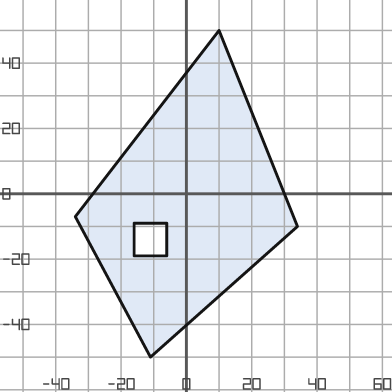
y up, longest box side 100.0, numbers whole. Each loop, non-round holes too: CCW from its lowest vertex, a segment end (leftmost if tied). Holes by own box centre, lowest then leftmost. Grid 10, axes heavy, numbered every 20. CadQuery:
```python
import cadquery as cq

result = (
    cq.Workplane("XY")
    .moveTo(-11.0, -50.0)
    .lineTo(34.0, -10.0)
    .lineTo(10.0, 50.0)
    .lineTo(-34.0, -7.0)
    .close()
    .moveTo(-16.0, -19.0)
    .lineTo(-6.0, -19.0)
    .lineTo(-6.0, -9.0)
    .lineTo(-16.0, -9.0)
    .close()
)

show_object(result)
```